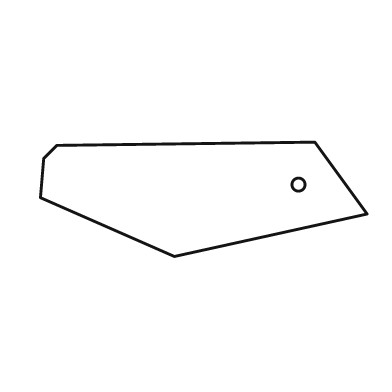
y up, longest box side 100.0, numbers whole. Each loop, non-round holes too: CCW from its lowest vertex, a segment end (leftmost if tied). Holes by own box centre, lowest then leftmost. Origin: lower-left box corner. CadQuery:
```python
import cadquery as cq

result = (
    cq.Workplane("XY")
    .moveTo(41.0, 0.0)
    .lineTo(100.0, 13.0)
    .lineTo(84.0, 35.0)
    .lineTo(5.0, 34.0)
    .lineTo(1.0, 30.0)
    .lineTo(0.0, 18.0)
    .close()
    .moveTo(79.0, 22.0)
    .circle(2.0)
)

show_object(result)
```